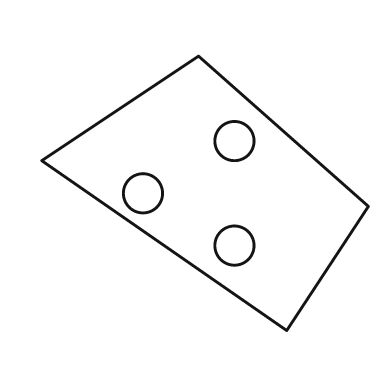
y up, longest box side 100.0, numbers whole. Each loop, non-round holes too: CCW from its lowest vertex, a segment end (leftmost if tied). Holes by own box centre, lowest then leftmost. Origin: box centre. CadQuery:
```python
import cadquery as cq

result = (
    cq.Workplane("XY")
    .moveTo(25.0, -42.0)
    .lineTo(50.0, -4.0)
    .lineTo(-2.0, 42.0)
    .lineTo(-50.0, 10.0)
    .close()
    .moveTo(9.0, -16.0)
    .circle(6.0)
    .moveTo(-19.0, 0.0)
    .circle(6.0)
    .moveTo(9.0, 16.0)
    .circle(6.0)
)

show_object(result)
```